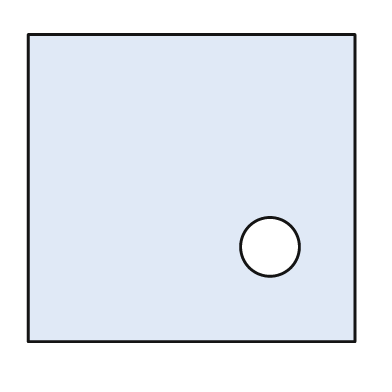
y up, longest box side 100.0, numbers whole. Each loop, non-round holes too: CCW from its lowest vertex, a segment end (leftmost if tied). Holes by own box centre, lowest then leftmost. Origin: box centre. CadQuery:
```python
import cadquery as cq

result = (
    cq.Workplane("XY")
    .moveTo(-50.0, -47.0)
    .lineTo(50.0, -47.0)
    .lineTo(50.0, 47.0)
    .lineTo(-50.0, 47.0)
    .close()
    .moveTo(24.0, -18.0)
    .circle(9.0)
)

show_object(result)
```